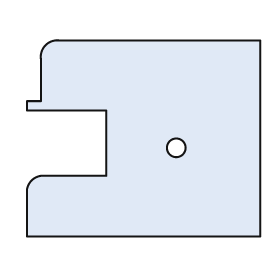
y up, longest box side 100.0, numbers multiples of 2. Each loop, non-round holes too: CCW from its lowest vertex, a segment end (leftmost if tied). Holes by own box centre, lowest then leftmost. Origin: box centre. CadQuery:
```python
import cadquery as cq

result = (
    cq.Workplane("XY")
    .moveTo(-50.0, -42.0)
    .lineTo(50.0, -42.0)
    .lineTo(50.0, 42.0)
    .lineTo(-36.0, 42.0)
    .threePointArc((-42.0, 40.0), (-44.0, 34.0))
    .lineTo(-44.0, 16.0)
    .lineTo(-50.0, 16.0)
    .lineTo(-50.0, 12.0)
    .lineTo(-16.0, 12.0)
    .lineTo(-16.0, -16.0)
    .lineTo(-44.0, -16.0)
    .threePointArc((-48.0, -18.0), (-50.0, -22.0))
    .close()
    .moveTo(14.0, -4.0)
    .circle(4.0)
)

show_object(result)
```